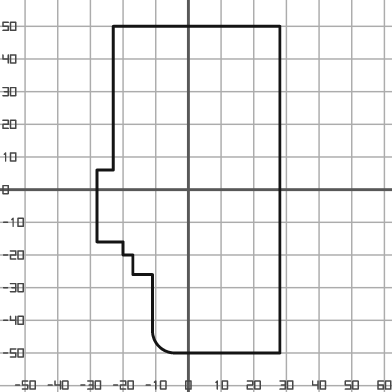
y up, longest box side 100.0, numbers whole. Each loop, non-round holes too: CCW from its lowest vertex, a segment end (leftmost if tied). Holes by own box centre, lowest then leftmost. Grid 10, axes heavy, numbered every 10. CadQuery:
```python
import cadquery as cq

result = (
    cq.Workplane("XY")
    .moveTo(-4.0, -50.0)
    .lineTo(28.0, -50.0)
    .lineTo(28.0, 50.0)
    .lineTo(-23.0, 50.0)
    .lineTo(-23.0, 6.0)
    .lineTo(-28.0, 6.0)
    .lineTo(-28.0, -16.0)
    .lineTo(-20.0, -16.0)
    .lineTo(-20.0, -20.0)
    .lineTo(-17.0, -20.0)
    .lineTo(-17.0, -26.0)
    .lineTo(-11.0, -26.0)
    .lineTo(-11.0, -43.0)
    .threePointArc((-9.0, -48.0), (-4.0, -50.0))
    .close()
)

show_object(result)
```